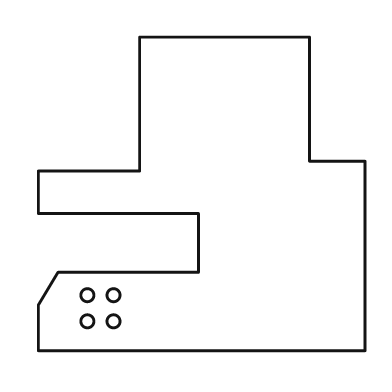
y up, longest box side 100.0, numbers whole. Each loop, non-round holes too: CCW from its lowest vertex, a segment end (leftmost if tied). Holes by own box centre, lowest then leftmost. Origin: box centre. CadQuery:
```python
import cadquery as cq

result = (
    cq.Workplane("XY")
    .moveTo(-50.0, -48.0)
    .lineTo(50.0, -48.0)
    .lineTo(50.0, 10.0)
    .lineTo(33.0, 10.0)
    .lineTo(33.0, 48.0)
    .lineTo(-19.0, 48.0)
    .lineTo(-19.0, 7.0)
    .lineTo(-50.0, 7.0)
    .lineTo(-50.0, -6.0)
    .lineTo(-1.0, -6.0)
    .lineTo(-1.0, -24.0)
    .lineTo(-44.0, -24.0)
    .lineTo(-50.0, -34.0)
    .close()
    .moveTo(-35.0, -39.0)
    .circle(2.0)
    .moveTo(-27.0, -39.0)
    .circle(2.0)
    .moveTo(-35.0, -31.0)
    .circle(2.0)
    .moveTo(-27.0, -31.0)
    .circle(2.0)
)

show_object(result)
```